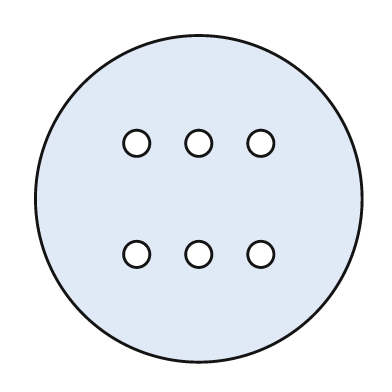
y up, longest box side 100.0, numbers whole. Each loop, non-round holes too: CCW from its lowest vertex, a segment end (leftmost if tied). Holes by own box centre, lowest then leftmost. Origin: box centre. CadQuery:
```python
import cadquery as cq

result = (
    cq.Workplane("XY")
    .moveTo(0.0, 0.0)
    .circle(50.0)
    .moveTo(-19.0, -17.0)
    .circle(4.0)
    .moveTo(0.0, -17.0)
    .circle(4.0)
    .moveTo(19.0, -17.0)
    .circle(4.0)
    .moveTo(-19.0, 17.0)
    .circle(4.0)
    .moveTo(0.0, 17.0)
    .circle(4.0)
    .moveTo(19.0, 17.0)
    .circle(4.0)
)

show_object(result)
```